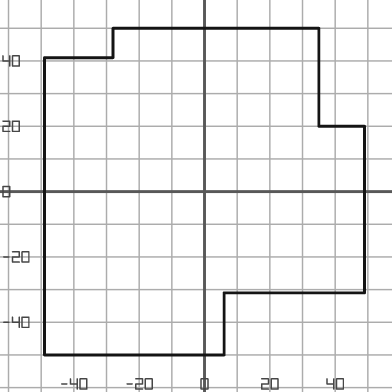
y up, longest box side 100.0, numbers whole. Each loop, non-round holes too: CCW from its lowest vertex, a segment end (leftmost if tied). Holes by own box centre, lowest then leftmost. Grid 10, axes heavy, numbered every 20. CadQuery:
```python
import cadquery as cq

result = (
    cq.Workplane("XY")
    .moveTo(-49.0, -50.0)
    .lineTo(6.0, -50.0)
    .lineTo(6.0, -31.0)
    .lineTo(49.0, -31.0)
    .lineTo(49.0, 20.0)
    .lineTo(35.0, 20.0)
    .lineTo(35.0, 50.0)
    .lineTo(-28.0, 50.0)
    .lineTo(-28.0, 41.0)
    .lineTo(-49.0, 41.0)
    .close()
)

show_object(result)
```